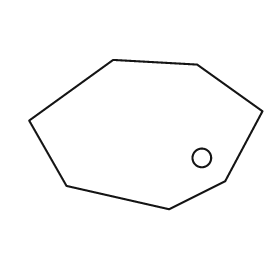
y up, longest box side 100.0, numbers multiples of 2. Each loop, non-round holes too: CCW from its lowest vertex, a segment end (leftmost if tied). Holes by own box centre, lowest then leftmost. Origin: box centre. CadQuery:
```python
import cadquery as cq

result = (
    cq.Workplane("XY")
    .moveTo(10.0, -32.0)
    .lineTo(34.0, -20.0)
    .lineTo(50.0, 10.0)
    .lineTo(22.0, 30.0)
    .lineTo(-14.0, 32.0)
    .lineTo(-50.0, 6.0)
    .lineTo(-34.0, -22.0)
    .close()
    .moveTo(24.0, -10.0)
    .circle(4.0)
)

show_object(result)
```